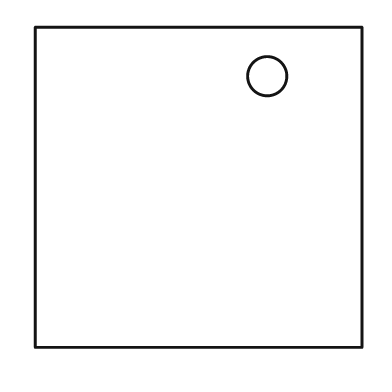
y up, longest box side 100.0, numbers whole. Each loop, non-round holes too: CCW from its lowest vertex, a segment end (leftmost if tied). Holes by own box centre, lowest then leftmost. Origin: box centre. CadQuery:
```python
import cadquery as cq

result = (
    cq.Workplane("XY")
    .moveTo(-50.0, -49.0)
    .lineTo(50.0, -49.0)
    .lineTo(50.0, 49.0)
    .lineTo(-50.0, 49.0)
    .close()
    .moveTo(21.0, 34.0)
    .circle(6.0)
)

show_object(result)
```